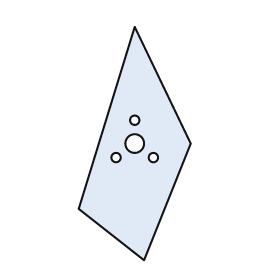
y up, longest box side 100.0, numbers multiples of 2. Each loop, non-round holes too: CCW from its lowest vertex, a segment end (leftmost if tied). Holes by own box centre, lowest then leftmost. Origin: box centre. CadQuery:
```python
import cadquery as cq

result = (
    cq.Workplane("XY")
    .moveTo(4.0, -50.0)
    .lineTo(24.0, 0.0)
    .lineTo(0.0, 50.0)
    .lineTo(-24.0, -28.0)
    .close()
    .moveTo(-8.0, -6.0)
    .circle(2.0)
    .moveTo(8.0, -6.0)
    .circle(2.0)
    .moveTo(0.0, 0.0)
    .circle(4.0)
    .moveTo(0.0, 10.0)
    .circle(2.0)
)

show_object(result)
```